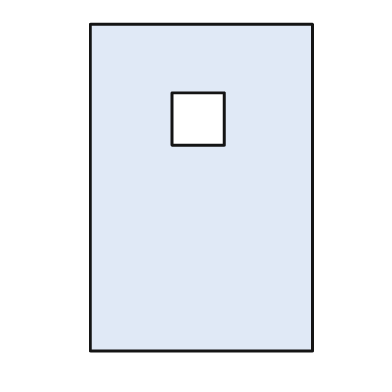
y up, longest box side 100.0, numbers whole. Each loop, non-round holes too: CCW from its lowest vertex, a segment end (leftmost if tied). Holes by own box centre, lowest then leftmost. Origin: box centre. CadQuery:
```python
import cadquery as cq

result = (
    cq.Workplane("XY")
    .moveTo(-34.0, -50.0)
    .lineTo(34.0, -50.0)
    .lineTo(34.0, 50.0)
    .lineTo(-34.0, 50.0)
    .close()
    .moveTo(-9.0, 13.0)
    .lineTo(7.0, 13.0)
    .lineTo(7.0, 29.0)
    .lineTo(-9.0, 29.0)
    .close()
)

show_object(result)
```